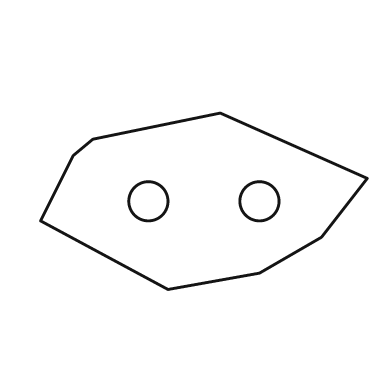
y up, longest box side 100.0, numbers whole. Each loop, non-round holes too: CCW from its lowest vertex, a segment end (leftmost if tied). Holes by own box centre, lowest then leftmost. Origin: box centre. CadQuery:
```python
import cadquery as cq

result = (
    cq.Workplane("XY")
    .moveTo(-11.0, -27.0)
    .lineTo(17.0, -22.0)
    .lineTo(36.0, -11.0)
    .lineTo(50.0, 7.0)
    .lineTo(5.0, 27.0)
    .lineTo(-34.0, 19.0)
    .lineTo(-40.0, 14.0)
    .lineTo(-50.0, -6.0)
    .close()
    .moveTo(-17.0, 0.0)
    .circle(6.0)
    .moveTo(17.0, 0.0)
    .circle(6.0)
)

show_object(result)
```